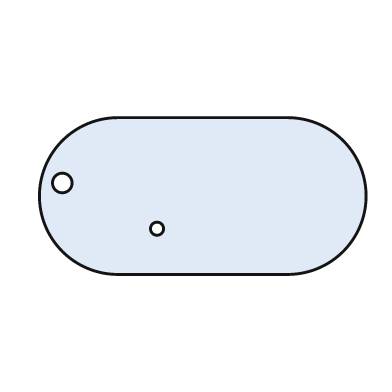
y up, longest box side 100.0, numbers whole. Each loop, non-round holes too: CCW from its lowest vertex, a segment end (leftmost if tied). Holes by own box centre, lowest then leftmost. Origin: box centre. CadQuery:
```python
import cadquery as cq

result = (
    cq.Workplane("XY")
    .moveTo(-26.0, -24.0)
    .lineTo(26.0, -24.0)
    .threePointArc((50.0, 0.0), (26.0, 24.0))
    .lineTo(-26.0, 24.0)
    .threePointArc((-50.0, 0.0), (-26.0, -24.0))
    .close()
    .moveTo(-14.0, -10.0)
    .circle(2.0)
    .moveTo(-43.0, 4.0)
    .circle(3.0)
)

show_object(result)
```